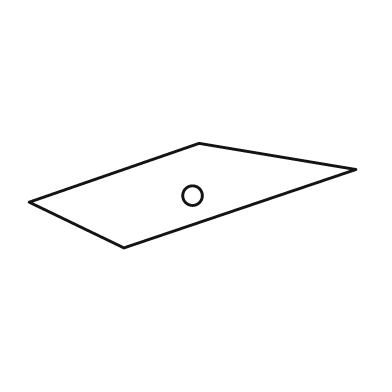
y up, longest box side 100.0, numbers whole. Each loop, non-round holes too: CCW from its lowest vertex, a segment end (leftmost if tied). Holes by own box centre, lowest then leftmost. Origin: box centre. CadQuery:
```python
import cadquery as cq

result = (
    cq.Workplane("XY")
    .moveTo(-21.0, -16.0)
    .lineTo(50.0, 8.0)
    .lineTo(2.0, 16.0)
    .lineTo(-50.0, -2.0)
    .close()
    .moveTo(0.0, 0.0)
    .circle(3.0)
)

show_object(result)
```